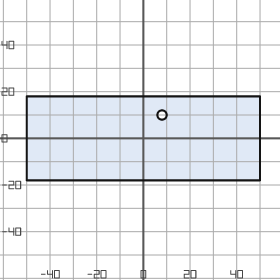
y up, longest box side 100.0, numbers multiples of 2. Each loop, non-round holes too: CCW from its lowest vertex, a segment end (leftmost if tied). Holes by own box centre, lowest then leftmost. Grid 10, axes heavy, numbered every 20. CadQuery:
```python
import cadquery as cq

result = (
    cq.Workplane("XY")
    .moveTo(-50.0, -18.0)
    .lineTo(50.0, -18.0)
    .lineTo(50.0, 18.0)
    .lineTo(-50.0, 18.0)
    .close()
    .moveTo(8.0, 10.0)
    .circle(2.0)
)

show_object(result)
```